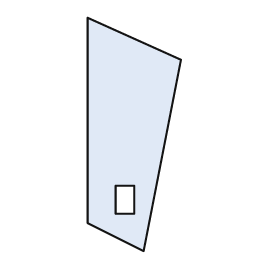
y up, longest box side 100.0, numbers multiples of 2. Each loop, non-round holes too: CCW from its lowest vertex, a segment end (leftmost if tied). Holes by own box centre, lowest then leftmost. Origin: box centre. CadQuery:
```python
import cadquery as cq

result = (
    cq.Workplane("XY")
    .moveTo(4.0, -50.0)
    .lineTo(20.0, 32.0)
    .lineTo(-20.0, 50.0)
    .lineTo(-20.0, -38.0)
    .close()
    .moveTo(-8.0, -34.0)
    .lineTo(0.0, -34.0)
    .lineTo(0.0, -22.0)
    .lineTo(-8.0, -22.0)
    .close()
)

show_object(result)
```